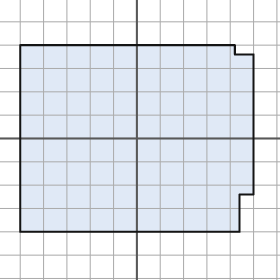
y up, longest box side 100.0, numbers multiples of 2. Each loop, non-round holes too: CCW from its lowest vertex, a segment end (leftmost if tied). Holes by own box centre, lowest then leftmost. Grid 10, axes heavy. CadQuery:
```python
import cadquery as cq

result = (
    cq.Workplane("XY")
    .moveTo(-50.0, -40.0)
    .lineTo(44.0, -40.0)
    .lineTo(44.0, -24.0)
    .lineTo(50.0, -24.0)
    .lineTo(50.0, 36.0)
    .lineTo(42.0, 36.0)
    .lineTo(42.0, 40.0)
    .lineTo(-50.0, 40.0)
    .close()
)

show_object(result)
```